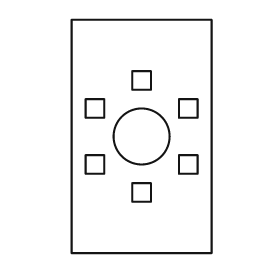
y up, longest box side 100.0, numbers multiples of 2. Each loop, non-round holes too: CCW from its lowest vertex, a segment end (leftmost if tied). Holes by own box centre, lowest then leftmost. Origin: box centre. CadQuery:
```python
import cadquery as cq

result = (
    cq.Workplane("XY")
    .moveTo(-30.0, -50.0)
    .lineTo(30.0, -50.0)
    .lineTo(30.0, 50.0)
    .lineTo(-30.0, 50.0)
    .close()
    .moveTo(-4.0, -28.0)
    .lineTo(4.0, -28.0)
    .lineTo(4.0, -20.0)
    .lineTo(-4.0, -20.0)
    .close()
    .moveTo(-24.0, -16.0)
    .lineTo(-16.0, -16.0)
    .lineTo(-16.0, -8.0)
    .lineTo(-24.0, -8.0)
    .close()
    .moveTo(16.0, -16.0)
    .lineTo(24.0, -16.0)
    .lineTo(24.0, -8.0)
    .lineTo(16.0, -8.0)
    .close()
    .moveTo(0.0, 0.0)
    .circle(12.0)
    .moveTo(-24.0, 8.0)
    .lineTo(-16.0, 8.0)
    .lineTo(-16.0, 16.0)
    .lineTo(-24.0, 16.0)
    .close()
    .moveTo(16.0, 8.0)
    .lineTo(24.0, 8.0)
    .lineTo(24.0, 16.0)
    .lineTo(16.0, 16.0)
    .close()
    .moveTo(-4.0, 20.0)
    .lineTo(4.0, 20.0)
    .lineTo(4.0, 28.0)
    .lineTo(-4.0, 28.0)
    .close()
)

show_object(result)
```